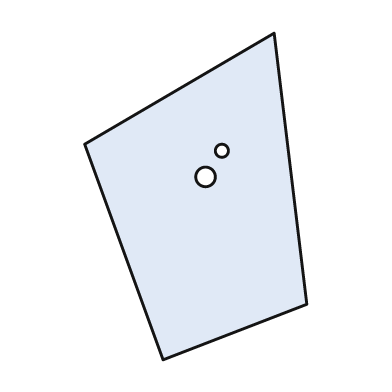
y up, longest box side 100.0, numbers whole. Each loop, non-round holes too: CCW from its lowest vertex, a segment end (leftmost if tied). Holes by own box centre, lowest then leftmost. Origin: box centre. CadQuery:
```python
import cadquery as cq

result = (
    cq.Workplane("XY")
    .moveTo(-10.0, -50.0)
    .lineTo(34.0, -33.0)
    .lineTo(24.0, 50.0)
    .lineTo(-34.0, 16.0)
    .close()
    .moveTo(3.0, 6.0)
    .circle(3.0)
    .moveTo(8.0, 14.0)
    .circle(2.0)
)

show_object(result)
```